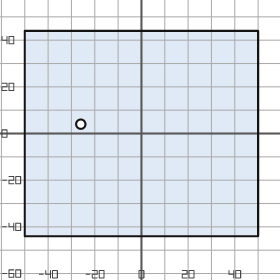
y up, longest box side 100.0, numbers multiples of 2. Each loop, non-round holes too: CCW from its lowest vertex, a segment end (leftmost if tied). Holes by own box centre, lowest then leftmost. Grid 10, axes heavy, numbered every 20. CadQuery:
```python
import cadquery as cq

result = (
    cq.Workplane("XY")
    .moveTo(-50.0, -44.0)
    .lineTo(50.0, -44.0)
    .lineTo(50.0, 44.0)
    .lineTo(-50.0, 44.0)
    .close()
    .moveTo(-26.0, 4.0)
    .circle(2.0)
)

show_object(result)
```